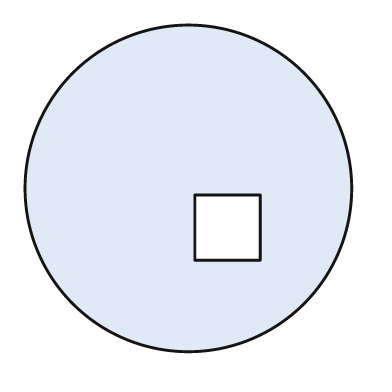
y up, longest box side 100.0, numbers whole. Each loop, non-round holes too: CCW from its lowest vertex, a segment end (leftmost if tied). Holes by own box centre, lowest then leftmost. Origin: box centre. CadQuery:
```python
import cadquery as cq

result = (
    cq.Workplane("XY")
    .moveTo(0.0, 0.0)
    .circle(50.0)
    .moveTo(2.0, -22.0)
    .lineTo(22.0, -22.0)
    .lineTo(22.0, -2.0)
    .lineTo(2.0, -2.0)
    .close()
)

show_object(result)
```